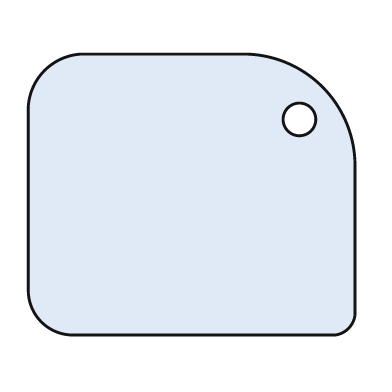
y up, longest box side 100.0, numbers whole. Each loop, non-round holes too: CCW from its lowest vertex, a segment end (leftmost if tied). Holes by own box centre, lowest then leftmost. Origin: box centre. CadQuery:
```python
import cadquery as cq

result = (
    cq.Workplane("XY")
    .moveTo(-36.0, -43.0)
    .lineTo(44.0, -43.0)
    .threePointArc((48.0, -41.0), (50.0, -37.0))
    .lineTo(50.0, 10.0)
    .threePointArc((40.0, 33.0), (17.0, 43.0))
    .lineTo(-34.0, 43.0)
    .threePointArc((-45.0, 38.0), (-50.0, 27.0))
    .lineTo(-50.0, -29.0)
    .threePointArc((-46.0, -39.0), (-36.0, -43.0))
    .close()
    .moveTo(33.0, 23.0)
    .circle(5.0)
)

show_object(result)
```